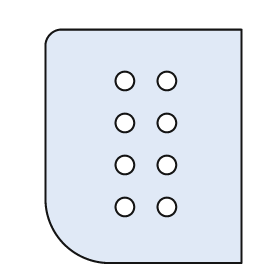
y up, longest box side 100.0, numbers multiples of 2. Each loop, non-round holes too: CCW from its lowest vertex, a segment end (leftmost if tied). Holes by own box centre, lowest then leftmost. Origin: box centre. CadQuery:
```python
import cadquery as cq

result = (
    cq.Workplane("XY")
    .moveTo(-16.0, -50.0)
    .lineTo(42.0, -50.0)
    .lineTo(42.0, 50.0)
    .lineTo(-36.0, 50.0)
    .threePointArc((-40.0, 48.0), (-42.0, 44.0))
    .lineTo(-42.0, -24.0)
    .threePointArc((-34.0, -42.0), (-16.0, -50.0))
    .close()
    .moveTo(-8.0, -26.0)
    .circle(4.0)
    .moveTo(10.0, -26.0)
    .circle(4.0)
    .moveTo(-8.0, -8.0)
    .circle(4.0)
    .moveTo(10.0, -8.0)
    .circle(4.0)
    .moveTo(-8.0, 10.0)
    .circle(4.0)
    .moveTo(10.0, 10.0)
    .circle(4.0)
    .moveTo(-8.0, 28.0)
    .circle(4.0)
    .moveTo(10.0, 28.0)
    .circle(4.0)
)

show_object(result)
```